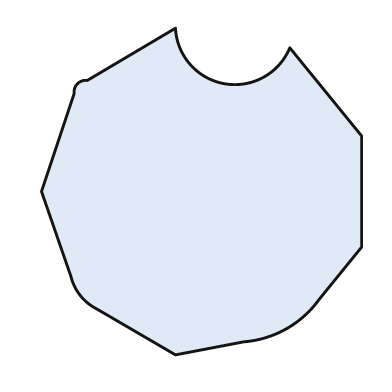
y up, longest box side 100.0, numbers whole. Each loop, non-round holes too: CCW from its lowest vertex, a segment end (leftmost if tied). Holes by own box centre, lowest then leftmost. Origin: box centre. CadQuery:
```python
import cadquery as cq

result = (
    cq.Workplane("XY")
    .moveTo(-8.0, -50.0)
    .lineTo(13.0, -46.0)
    .threePointArc((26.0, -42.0), (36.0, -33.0))
    .lineTo(49.0, -17.0)
    .lineTo(49.0, 17.0)
    .lineTo(27.0, 44.0)
    .threePointArc((7.0, 33.0), (-8.0, 50.0))
    .lineTo(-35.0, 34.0)
    .threePointArc((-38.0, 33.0), (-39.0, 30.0))
    .lineTo(-49.0, 0.0)
    .lineTo(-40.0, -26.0)
    .threePointArc((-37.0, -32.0), (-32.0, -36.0))
    .close()
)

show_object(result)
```